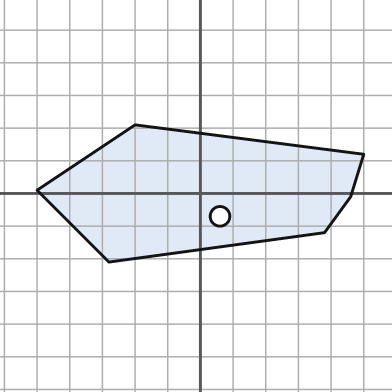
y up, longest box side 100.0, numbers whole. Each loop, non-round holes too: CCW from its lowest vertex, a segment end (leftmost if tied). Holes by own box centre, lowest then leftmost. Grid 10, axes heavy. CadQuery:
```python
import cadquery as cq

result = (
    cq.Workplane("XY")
    .moveTo(-28.0, -21.0)
    .lineTo(38.0, -12.0)
    .lineTo(46.0, -1.0)
    .lineTo(50.0, 12.0)
    .lineTo(-20.0, 21.0)
    .lineTo(-50.0, 1.0)
    .close()
    .moveTo(6.0, -7.0)
    .circle(3.0)
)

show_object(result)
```